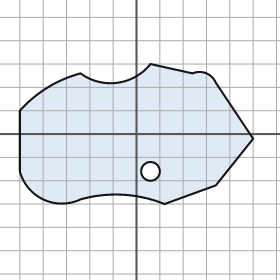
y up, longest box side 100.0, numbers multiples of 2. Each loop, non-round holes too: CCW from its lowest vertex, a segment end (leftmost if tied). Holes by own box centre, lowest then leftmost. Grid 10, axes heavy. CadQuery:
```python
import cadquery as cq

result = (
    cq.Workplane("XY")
    .moveTo(12.0, -30.0)
    .lineTo(34.0, -22.0)
    .lineTo(50.0, -2.0)
    .lineTo(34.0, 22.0)
    .threePointArc((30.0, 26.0), (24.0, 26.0))
    .lineTo(6.0, 30.0)
    .threePointArc((-8.0, 22.0), (-24.0, 26.0))
    .threePointArc((-38.0, 20.0), (-50.0, 10.0))
    .lineTo(-50.0, -16.0)
    .threePointArc((-40.0, -28.0), (-24.0, -28.0))
    .threePointArc((-6.0, -26.0), (12.0, -30.0))
    .close()
    .moveTo(6.0, -16.0)
    .circle(4.0)
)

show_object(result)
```